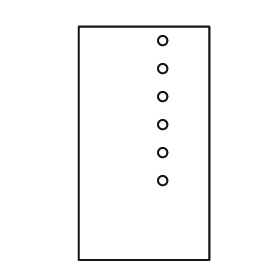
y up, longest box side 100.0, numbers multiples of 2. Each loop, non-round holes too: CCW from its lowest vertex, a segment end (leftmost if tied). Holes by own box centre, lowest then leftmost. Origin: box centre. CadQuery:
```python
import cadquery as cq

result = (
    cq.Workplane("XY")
    .moveTo(-28.0, -50.0)
    .lineTo(28.0, -50.0)
    .lineTo(28.0, 50.0)
    .lineTo(-28.0, 50.0)
    .close()
    .moveTo(8.0, -16.0)
    .circle(2.0)
    .moveTo(8.0, -4.0)
    .circle(2.0)
    .moveTo(8.0, 8.0)
    .circle(2.0)
    .moveTo(8.0, 20.0)
    .circle(2.0)
    .moveTo(8.0, 32.0)
    .circle(2.0)
    .moveTo(8.0, 44.0)
    .circle(2.0)
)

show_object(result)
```